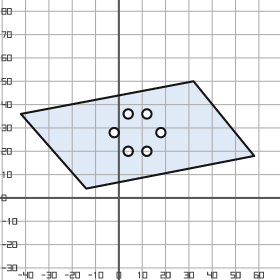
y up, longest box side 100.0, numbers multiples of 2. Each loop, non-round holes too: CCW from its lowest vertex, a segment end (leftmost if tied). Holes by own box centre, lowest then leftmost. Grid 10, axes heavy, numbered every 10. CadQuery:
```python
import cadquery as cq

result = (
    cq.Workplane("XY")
    .moveTo(-14.0, 4.0)
    .lineTo(58.0, 18.0)
    .lineTo(32.0, 50.0)
    .lineTo(-42.0, 36.0)
    .close()
    .moveTo(4.0, 20.0)
    .circle(2.0)
    .moveTo(12.0, 20.0)
    .circle(2.0)
    .moveTo(-2.0, 28.0)
    .circle(2.0)
    .moveTo(18.0, 28.0)
    .circle(2.0)
    .moveTo(4.0, 36.0)
    .circle(2.0)
    .moveTo(12.0, 36.0)
    .circle(2.0)
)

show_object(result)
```